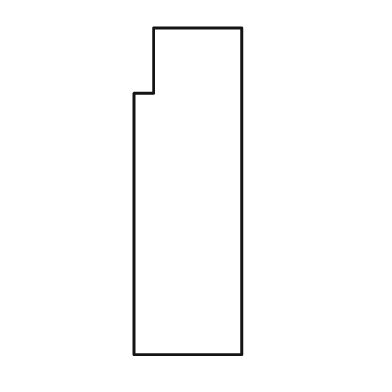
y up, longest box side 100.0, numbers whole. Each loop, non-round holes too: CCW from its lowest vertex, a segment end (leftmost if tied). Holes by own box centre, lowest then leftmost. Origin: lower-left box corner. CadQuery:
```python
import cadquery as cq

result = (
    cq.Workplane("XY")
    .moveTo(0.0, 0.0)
    .lineTo(33.0, 0.0)
    .lineTo(33.0, 100.0)
    .lineTo(6.0, 100.0)
    .lineTo(6.0, 80.0)
    .lineTo(0.0, 80.0)
    .close()
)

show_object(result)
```